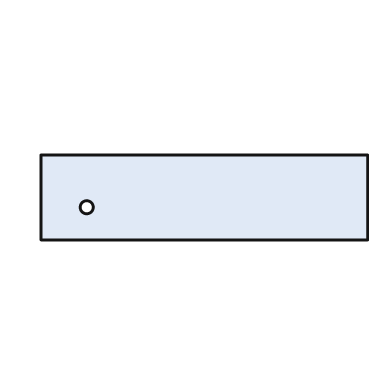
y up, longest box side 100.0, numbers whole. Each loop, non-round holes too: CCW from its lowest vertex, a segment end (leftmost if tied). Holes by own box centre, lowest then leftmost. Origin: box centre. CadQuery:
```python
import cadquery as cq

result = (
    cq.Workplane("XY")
    .moveTo(-50.0, -13.0)
    .lineTo(50.0, -13.0)
    .lineTo(50.0, 13.0)
    .lineTo(-50.0, 13.0)
    .close()
    .moveTo(-36.0, -3.0)
    .circle(2.0)
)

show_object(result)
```